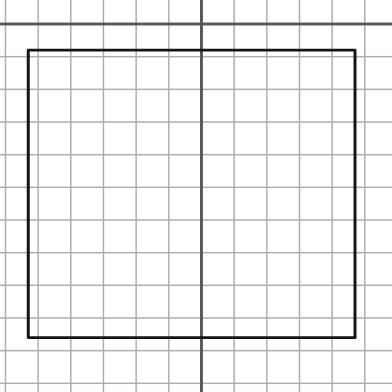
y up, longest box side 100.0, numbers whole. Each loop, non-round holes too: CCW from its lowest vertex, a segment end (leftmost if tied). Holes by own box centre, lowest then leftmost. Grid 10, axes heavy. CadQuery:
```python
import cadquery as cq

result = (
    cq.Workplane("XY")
    .moveTo(-53.0, -96.0)
    .lineTo(47.0, -96.0)
    .lineTo(47.0, -8.0)
    .lineTo(-53.0, -8.0)
    .close()
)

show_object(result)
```